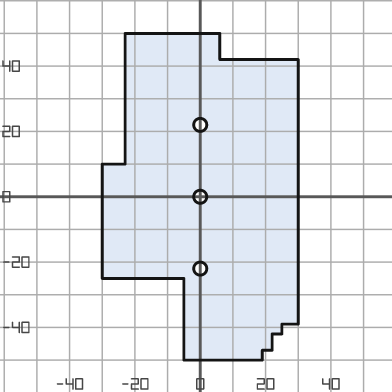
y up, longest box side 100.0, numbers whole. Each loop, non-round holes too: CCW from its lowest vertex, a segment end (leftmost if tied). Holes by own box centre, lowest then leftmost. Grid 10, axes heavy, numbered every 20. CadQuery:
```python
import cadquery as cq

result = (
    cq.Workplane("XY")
    .moveTo(-5.0, -50.0)
    .lineTo(19.0, -50.0)
    .lineTo(19.0, -47.0)
    .lineTo(22.0, -47.0)
    .lineTo(22.0, -42.0)
    .lineTo(25.0, -42.0)
    .lineTo(25.0, -39.0)
    .lineTo(30.0, -39.0)
    .lineTo(30.0, 42.0)
    .lineTo(6.0, 42.0)
    .lineTo(6.0, 50.0)
    .lineTo(-23.0, 50.0)
    .lineTo(-23.0, 10.0)
    .lineTo(-30.0, 10.0)
    .lineTo(-30.0, -25.0)
    .lineTo(-5.0, -25.0)
    .close()
    .moveTo(0.0, -22.0)
    .circle(2.0)
    .moveTo(0.0, 0.0)
    .circle(2.0)
    .moveTo(0.0, 22.0)
    .circle(2.0)
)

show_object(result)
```